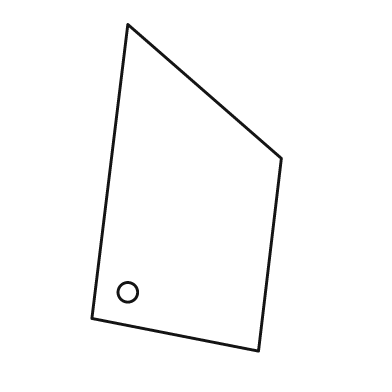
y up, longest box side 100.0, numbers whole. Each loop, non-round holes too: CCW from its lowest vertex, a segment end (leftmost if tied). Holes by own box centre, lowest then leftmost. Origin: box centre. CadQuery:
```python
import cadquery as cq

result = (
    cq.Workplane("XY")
    .moveTo(22.0, -50.0)
    .lineTo(29.0, 9.0)
    .lineTo(-18.0, 50.0)
    .lineTo(-29.0, -40.0)
    .close()
    .moveTo(-18.0, -32.0)
    .circle(3.0)
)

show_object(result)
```